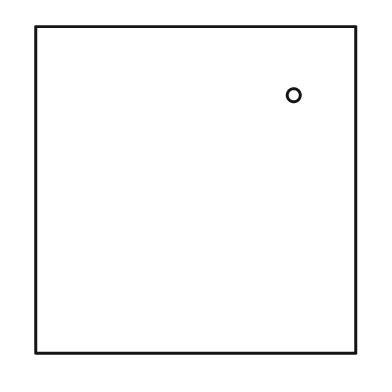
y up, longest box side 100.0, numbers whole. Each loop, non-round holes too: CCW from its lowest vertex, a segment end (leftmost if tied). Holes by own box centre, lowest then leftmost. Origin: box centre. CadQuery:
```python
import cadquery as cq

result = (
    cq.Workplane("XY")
    .moveTo(-49.0, -50.0)
    .lineTo(49.0, -50.0)
    .lineTo(49.0, 50.0)
    .lineTo(-49.0, 50.0)
    .close()
    .moveTo(30.0, 29.0)
    .circle(2.0)
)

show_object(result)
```